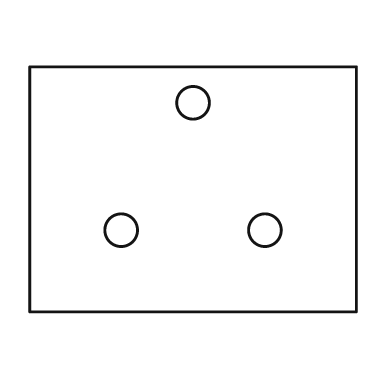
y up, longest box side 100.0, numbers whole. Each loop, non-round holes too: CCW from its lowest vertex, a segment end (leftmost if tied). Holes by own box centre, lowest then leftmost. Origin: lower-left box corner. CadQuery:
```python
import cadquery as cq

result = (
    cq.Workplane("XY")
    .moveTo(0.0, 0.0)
    .lineTo(100.0, 0.0)
    .lineTo(100.0, 75.0)
    .lineTo(0.0, 75.0)
    .close()
    .moveTo(28.0, 25.0)
    .circle(5.0)
    .moveTo(72.0, 25.0)
    .circle(5.0)
    .moveTo(50.0, 64.0)
    .circle(5.0)
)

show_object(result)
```